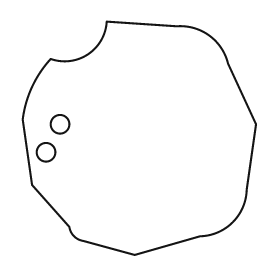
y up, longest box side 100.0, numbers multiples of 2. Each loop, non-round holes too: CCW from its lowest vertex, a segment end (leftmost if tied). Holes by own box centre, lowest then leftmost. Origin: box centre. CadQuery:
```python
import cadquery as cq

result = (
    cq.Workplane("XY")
    .moveTo(-2.0, -50.0)
    .lineTo(26.0, -42.0)
    .threePointArc((40.0, -36.0), (46.0, -22.0))
    .lineTo(50.0, 6.0)
    .lineTo(38.0, 32.0)
    .threePointArc((30.0, 44.0), (16.0, 48.0))
    .lineTo(-14.0, 50.0)
    .threePointArc((-22.0, 36.0), (-38.0, 34.0))
    .threePointArc((-46.0, 22.0), (-50.0, 8.0))
    .lineTo(-46.0, -20.0)
    .lineTo(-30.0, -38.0)
    .threePointArc((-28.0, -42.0), (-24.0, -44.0))
    .close()
    .moveTo(-40.0, -6.0)
    .circle(4.0)
    .moveTo(-34.0, 6.0)
    .circle(4.0)
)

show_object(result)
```